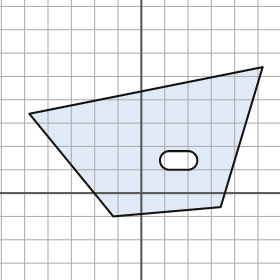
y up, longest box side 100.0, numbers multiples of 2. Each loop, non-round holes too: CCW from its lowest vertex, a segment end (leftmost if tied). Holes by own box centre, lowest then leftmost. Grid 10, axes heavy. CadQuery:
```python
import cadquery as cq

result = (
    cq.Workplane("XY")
    .moveTo(-12.0, -10.0)
    .lineTo(34.0, -6.0)
    .lineTo(52.0, 54.0)
    .lineTo(-48.0, 34.0)
    .close()
    .moveTo(12.0, 10.0)
    .lineTo(20.0, 10.0)
    .threePointArc((24.0, 14.0), (20.0, 18.0))
    .lineTo(12.0, 18.0)
    .threePointArc((8.0, 14.0), (12.0, 10.0))
    .close()
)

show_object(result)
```